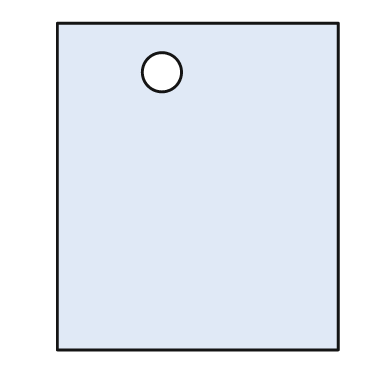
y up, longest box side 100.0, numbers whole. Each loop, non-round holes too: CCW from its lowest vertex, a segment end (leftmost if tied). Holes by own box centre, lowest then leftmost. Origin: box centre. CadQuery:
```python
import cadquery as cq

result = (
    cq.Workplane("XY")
    .moveTo(-43.0, -50.0)
    .lineTo(43.0, -50.0)
    .lineTo(43.0, 50.0)
    .lineTo(-43.0, 50.0)
    .close()
    .moveTo(-11.0, 35.0)
    .circle(6.0)
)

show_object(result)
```